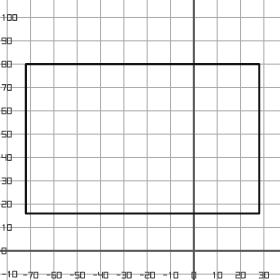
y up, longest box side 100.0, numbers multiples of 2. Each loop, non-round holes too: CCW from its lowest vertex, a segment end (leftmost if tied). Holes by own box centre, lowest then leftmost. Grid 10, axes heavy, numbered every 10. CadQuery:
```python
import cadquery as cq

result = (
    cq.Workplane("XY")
    .moveTo(-72.0, 16.0)
    .lineTo(28.0, 16.0)
    .lineTo(28.0, 80.0)
    .lineTo(-72.0, 80.0)
    .close()
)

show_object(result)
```